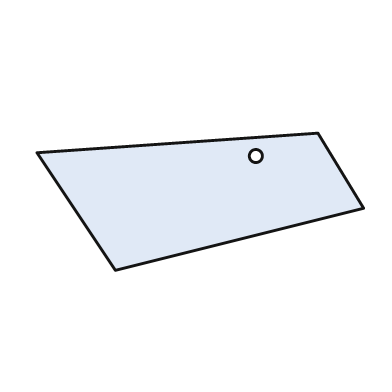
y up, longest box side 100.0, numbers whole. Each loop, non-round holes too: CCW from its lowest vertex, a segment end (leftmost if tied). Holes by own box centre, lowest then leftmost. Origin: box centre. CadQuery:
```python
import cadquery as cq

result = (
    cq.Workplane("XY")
    .moveTo(-26.0, -21.0)
    .lineTo(50.0, -2.0)
    .lineTo(36.0, 21.0)
    .lineTo(-50.0, 15.0)
    .close()
    .moveTo(17.0, 14.0)
    .circle(2.0)
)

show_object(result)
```